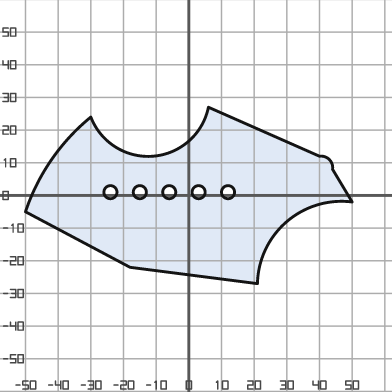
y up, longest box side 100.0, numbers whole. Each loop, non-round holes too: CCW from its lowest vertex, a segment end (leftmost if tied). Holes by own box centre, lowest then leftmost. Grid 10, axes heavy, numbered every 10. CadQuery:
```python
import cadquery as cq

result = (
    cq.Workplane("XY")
    .moveTo(21.0, -27.0)
    .threePointArc((30.0, -8.0), (50.0, -2.0))
    .lineTo(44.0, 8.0)
    .threePointArc((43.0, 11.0), (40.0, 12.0))
    .lineTo(6.0, 27.0)
    .threePointArc((-11.0, 12.0), (-30.0, 24.0))
    .threePointArc((-42.0, 11.0), (-50.0, -5.0))
    .lineTo(-18.0, -22.0)
    .close()
    .moveTo(-24.0, 1.0)
    .circle(2.0)
    .moveTo(-15.0, 1.0)
    .circle(2.0)
    .moveTo(-6.0, 1.0)
    .circle(2.0)
    .moveTo(3.0, 1.0)
    .circle(2.0)
    .moveTo(12.0, 1.0)
    .circle(2.0)
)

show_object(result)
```